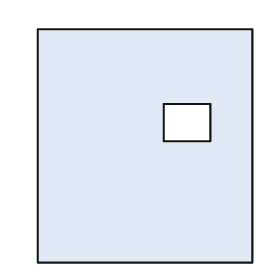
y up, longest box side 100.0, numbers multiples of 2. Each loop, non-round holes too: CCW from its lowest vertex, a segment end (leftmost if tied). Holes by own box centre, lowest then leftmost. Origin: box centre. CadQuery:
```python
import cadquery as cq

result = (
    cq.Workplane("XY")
    .moveTo(-46.0, -50.0)
    .lineTo(46.0, -50.0)
    .lineTo(46.0, 50.0)
    .lineTo(-46.0, 50.0)
    .close()
    .moveTo(8.0, 2.0)
    .lineTo(28.0, 2.0)
    .lineTo(28.0, 18.0)
    .lineTo(8.0, 18.0)
    .close()
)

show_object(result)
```